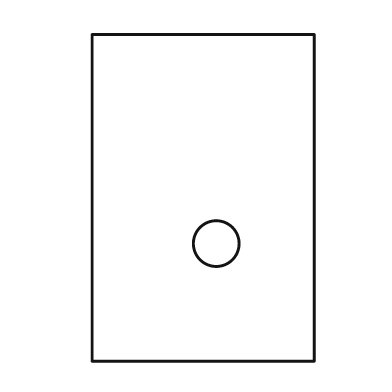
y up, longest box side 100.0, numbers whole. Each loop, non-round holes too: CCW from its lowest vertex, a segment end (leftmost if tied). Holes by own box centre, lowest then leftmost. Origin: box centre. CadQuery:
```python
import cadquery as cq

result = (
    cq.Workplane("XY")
    .moveTo(-34.0, -50.0)
    .lineTo(34.0, -50.0)
    .lineTo(34.0, 50.0)
    .lineTo(-34.0, 50.0)
    .close()
    .moveTo(4.0, -14.0)
    .circle(7.0)
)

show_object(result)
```